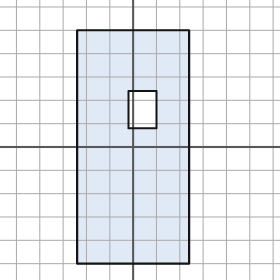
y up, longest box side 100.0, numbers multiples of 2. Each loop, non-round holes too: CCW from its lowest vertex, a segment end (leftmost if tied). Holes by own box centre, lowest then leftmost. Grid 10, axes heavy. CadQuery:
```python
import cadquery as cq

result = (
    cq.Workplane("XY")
    .moveTo(-24.0, -50.0)
    .lineTo(24.0, -50.0)
    .lineTo(24.0, 50.0)
    .lineTo(-24.0, 50.0)
    .close()
    .moveTo(-2.0, 8.0)
    .lineTo(10.0, 8.0)
    .lineTo(10.0, 24.0)
    .lineTo(-2.0, 24.0)
    .close()
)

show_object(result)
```